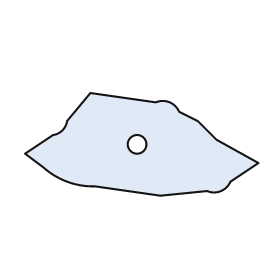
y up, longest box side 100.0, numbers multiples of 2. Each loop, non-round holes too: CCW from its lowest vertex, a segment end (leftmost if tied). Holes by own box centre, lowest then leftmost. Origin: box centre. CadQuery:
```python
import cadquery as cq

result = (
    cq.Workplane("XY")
    .moveTo(8.0, -22.0)
    .lineTo(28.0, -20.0)
    .threePointArc((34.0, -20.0), (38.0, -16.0))
    .lineTo(50.0, -8.0)
    .lineTo(32.0, 2.0)
    .lineTo(24.0, 10.0)
    .lineTo(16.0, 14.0)
    .threePointArc((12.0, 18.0), (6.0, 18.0))
    .lineTo(-22.0, 22.0)
    .lineTo(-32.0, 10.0)
    .threePointArc((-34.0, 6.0), (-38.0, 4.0))
    .lineTo(-50.0, -4.0)
    .lineTo(-42.0, -10.0)
    .threePointArc((-32.0, -16.0), (-20.0, -18.0))
    .close()
    .moveTo(-2.0, 0.0)
    .circle(4.0)
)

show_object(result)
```